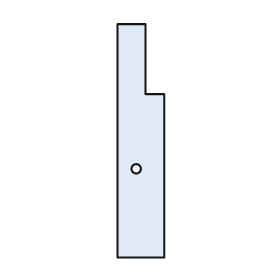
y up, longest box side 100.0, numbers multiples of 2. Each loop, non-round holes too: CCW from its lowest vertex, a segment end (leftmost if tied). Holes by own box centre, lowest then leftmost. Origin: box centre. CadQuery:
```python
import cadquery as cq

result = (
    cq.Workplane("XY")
    .moveTo(-10.0, -50.0)
    .lineTo(10.0, -50.0)
    .lineTo(10.0, 20.0)
    .lineTo(2.0, 20.0)
    .lineTo(2.0, 50.0)
    .lineTo(-10.0, 50.0)
    .close()
    .moveTo(-2.0, -12.0)
    .circle(2.0)
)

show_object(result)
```